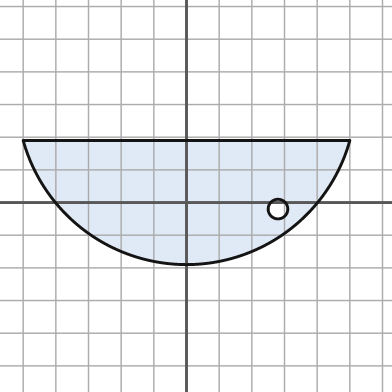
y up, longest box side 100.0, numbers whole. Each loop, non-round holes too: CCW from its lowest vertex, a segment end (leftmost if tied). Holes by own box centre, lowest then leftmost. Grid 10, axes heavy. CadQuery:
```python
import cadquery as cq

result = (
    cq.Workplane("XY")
    .moveTo(-50.0, 19.0)
    .threePointArc((0.0, -19.0), (50.0, 19.0))
    .close()
    .moveTo(28.0, -2.0)
    .circle(3.0)
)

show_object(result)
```